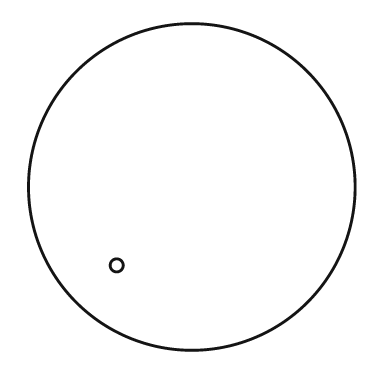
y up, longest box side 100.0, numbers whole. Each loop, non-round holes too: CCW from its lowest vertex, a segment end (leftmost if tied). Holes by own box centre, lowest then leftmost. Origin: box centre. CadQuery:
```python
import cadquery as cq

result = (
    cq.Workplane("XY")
    .moveTo(0.0, 0.0)
    .circle(50.0)
    .moveTo(-23.0, -24.0)
    .circle(2.0)
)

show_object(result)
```